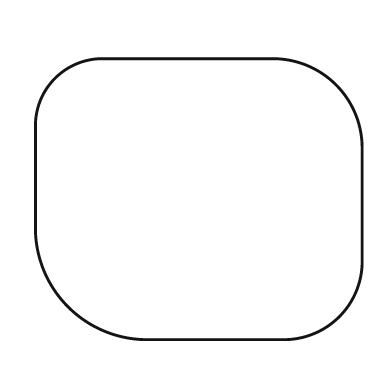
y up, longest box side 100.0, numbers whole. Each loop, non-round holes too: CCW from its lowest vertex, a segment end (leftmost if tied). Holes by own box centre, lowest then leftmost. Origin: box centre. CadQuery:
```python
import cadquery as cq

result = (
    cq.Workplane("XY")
    .moveTo(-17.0, -43.0)
    .lineTo(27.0, -43.0)
    .threePointArc((43.0, -36.0), (50.0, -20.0))
    .lineTo(50.0, 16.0)
    .threePointArc((42.0, 35.0), (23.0, 43.0))
    .lineTo(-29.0, 43.0)
    .threePointArc((-44.0, 37.0), (-50.0, 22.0))
    .lineTo(-50.0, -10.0)
    .threePointArc((-40.0, -33.0), (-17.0, -43.0))
    .close()
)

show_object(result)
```